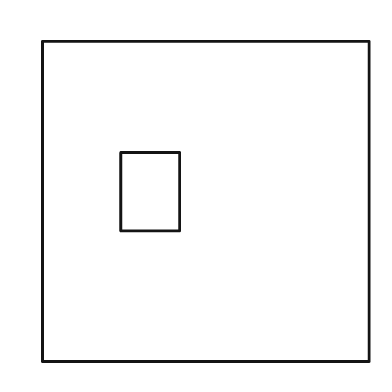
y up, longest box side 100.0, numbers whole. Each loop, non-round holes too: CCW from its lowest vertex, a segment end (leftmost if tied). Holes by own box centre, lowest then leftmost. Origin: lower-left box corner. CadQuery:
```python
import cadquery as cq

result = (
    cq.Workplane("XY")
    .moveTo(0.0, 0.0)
    .lineTo(100.0, 0.0)
    .lineTo(100.0, 98.0)
    .lineTo(0.0, 98.0)
    .close()
    .moveTo(24.0, 40.0)
    .lineTo(42.0, 40.0)
    .lineTo(42.0, 64.0)
    .lineTo(24.0, 64.0)
    .close()
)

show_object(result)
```